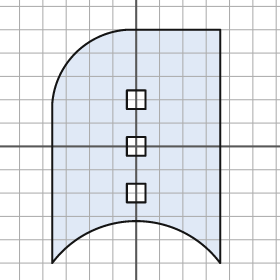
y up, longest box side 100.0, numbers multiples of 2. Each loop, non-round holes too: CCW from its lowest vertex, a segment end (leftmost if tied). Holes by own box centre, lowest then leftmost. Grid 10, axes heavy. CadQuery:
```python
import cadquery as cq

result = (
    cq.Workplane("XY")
    .moveTo(-36.0, -50.0)
    .threePointArc((0.0, -32.0), (36.0, -50.0))
    .lineTo(36.0, 50.0)
    .lineTo(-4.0, 50.0)
    .threePointArc((-26.0, 40.0), (-36.0, 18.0))
    .close()
    .moveTo(-4.0, -24.0)
    .lineTo(4.0, -24.0)
    .lineTo(4.0, -16.0)
    .lineTo(-4.0, -16.0)
    .close()
    .moveTo(-4.0, -4.0)
    .lineTo(4.0, -4.0)
    .lineTo(4.0, 4.0)
    .lineTo(-4.0, 4.0)
    .close()
    .moveTo(-4.0, 16.0)
    .lineTo(4.0, 16.0)
    .lineTo(4.0, 24.0)
    .lineTo(-4.0, 24.0)
    .close()
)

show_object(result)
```